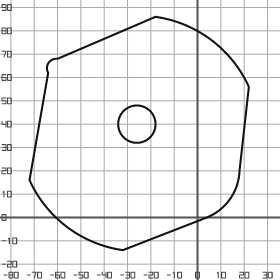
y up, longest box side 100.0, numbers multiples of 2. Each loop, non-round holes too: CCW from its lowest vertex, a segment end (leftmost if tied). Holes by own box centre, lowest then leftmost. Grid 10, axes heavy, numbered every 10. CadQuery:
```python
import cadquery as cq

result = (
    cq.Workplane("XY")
    .moveTo(-32.0, -14.0)
    .lineTo(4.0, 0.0)
    .threePointArc((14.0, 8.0), (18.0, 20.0))
    .lineTo(22.0, 56.0)
    .threePointArc((6.0, 76.0), (-18.0, 86.0))
    .lineTo(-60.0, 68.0)
    .threePointArc((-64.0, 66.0), (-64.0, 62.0))
    .lineTo(-72.0, 16.0)
    .threePointArc((-56.0, -4.0), (-32.0, -14.0))
    .close()
    .moveTo(-26.0, 40.0)
    .circle(8.0)
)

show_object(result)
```